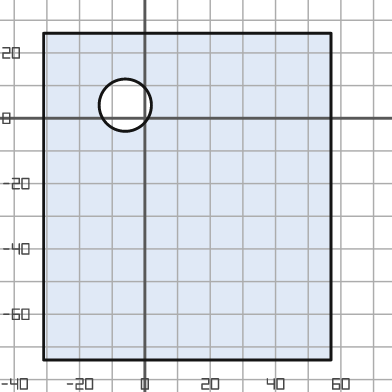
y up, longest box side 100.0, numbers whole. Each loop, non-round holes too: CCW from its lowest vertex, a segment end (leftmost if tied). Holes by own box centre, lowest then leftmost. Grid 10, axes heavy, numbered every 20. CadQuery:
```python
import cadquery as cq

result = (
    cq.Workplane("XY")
    .moveTo(-31.0, -74.0)
    .lineTo(57.0, -74.0)
    .lineTo(57.0, 26.0)
    .lineTo(-31.0, 26.0)
    .close()
    .moveTo(-6.0, 4.0)
    .circle(8.0)
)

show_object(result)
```